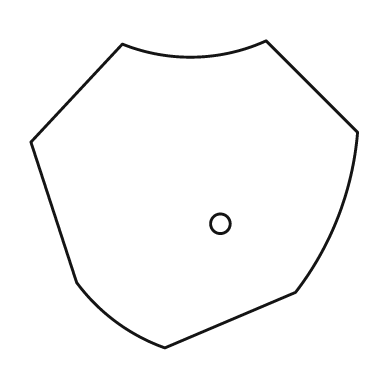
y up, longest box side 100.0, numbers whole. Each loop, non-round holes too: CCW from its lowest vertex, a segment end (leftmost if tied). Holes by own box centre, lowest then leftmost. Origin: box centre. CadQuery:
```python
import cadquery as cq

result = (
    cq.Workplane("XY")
    .moveTo(-9.0, -47.0)
    .lineTo(31.0, -30.0)
    .threePointArc((44.0, -7.0), (50.0, 19.0))
    .lineTo(22.0, 47.0)
    .threePointArc((0.0, 42.0), (-22.0, 46.0))
    .lineTo(-50.0, 16.0)
    .lineTo(-36.0, -27.0)
    .threePointArc((-24.0, -39.0), (-9.0, -47.0))
    .close()
    .moveTo(8.0, -9.0)
    .circle(3.0)
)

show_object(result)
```